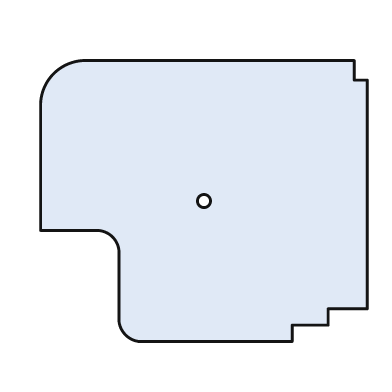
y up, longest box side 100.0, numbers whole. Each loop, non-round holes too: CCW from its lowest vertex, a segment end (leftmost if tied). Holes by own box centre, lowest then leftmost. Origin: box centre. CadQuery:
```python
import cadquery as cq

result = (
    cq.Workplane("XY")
    .moveTo(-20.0, -43.0)
    .lineTo(27.0, -43.0)
    .lineTo(27.0, -38.0)
    .lineTo(38.0, -38.0)
    .lineTo(38.0, -33.0)
    .lineTo(50.0, -33.0)
    .lineTo(50.0, 37.0)
    .lineTo(46.0, 37.0)
    .lineTo(46.0, 43.0)
    .lineTo(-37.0, 43.0)
    .threePointArc((-46.0, 39.0), (-50.0, 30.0))
    .lineTo(-50.0, -9.0)
    .lineTo(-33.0, -9.0)
    .threePointArc((-28.0, -11.0), (-26.0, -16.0))
    .lineTo(-26.0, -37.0)
    .threePointArc((-24.0, -41.0), (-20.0, -43.0))
    .close()
    .moveTo(0.0, 0.0)
    .circle(2.0)
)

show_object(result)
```